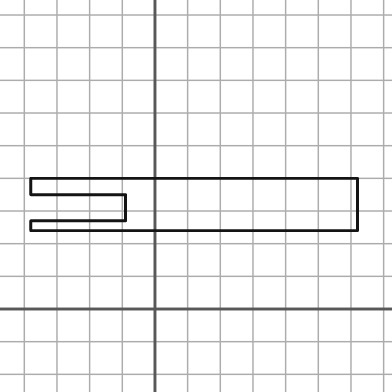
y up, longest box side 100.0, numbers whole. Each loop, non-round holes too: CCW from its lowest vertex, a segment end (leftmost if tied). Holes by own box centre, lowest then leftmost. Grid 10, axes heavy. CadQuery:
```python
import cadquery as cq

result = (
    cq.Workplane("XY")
    .moveTo(-38.0, 24.0)
    .lineTo(62.0, 24.0)
    .lineTo(62.0, 40.0)
    .lineTo(-38.0, 40.0)
    .lineTo(-38.0, 35.0)
    .lineTo(-9.0, 35.0)
    .lineTo(-9.0, 27.0)
    .lineTo(-38.0, 27.0)
    .close()
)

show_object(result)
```